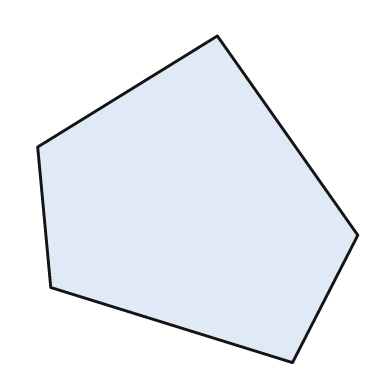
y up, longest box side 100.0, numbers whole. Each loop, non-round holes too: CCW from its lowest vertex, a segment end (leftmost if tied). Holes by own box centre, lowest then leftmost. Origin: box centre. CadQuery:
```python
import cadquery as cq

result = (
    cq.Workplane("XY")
    .moveTo(29.0, -50.0)
    .lineTo(49.0, -11.0)
    .lineTo(6.0, 50.0)
    .lineTo(-49.0, 16.0)
    .lineTo(-45.0, -27.0)
    .close()
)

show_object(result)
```